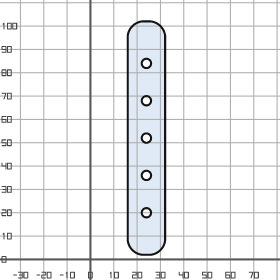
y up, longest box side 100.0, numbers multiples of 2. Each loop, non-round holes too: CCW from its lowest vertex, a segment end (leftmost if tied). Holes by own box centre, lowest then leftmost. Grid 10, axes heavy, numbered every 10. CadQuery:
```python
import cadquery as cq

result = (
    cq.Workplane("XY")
    .moveTo(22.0, 2.0)
    .lineTo(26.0, 2.0)
    .threePointArc((30.0, 4.0), (32.0, 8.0))
    .lineTo(32.0, 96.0)
    .threePointArc((30.0, 100.0), (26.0, 102.0))
    .lineTo(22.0, 102.0)
    .threePointArc((18.0, 100.0), (16.0, 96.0))
    .lineTo(16.0, 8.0)
    .threePointArc((18.0, 4.0), (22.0, 2.0))
    .close()
    .moveTo(24.0, 20.0)
    .circle(2.0)
    .moveTo(24.0, 36.0)
    .circle(2.0)
    .moveTo(24.0, 52.0)
    .circle(2.0)
    .moveTo(24.0, 68.0)
    .circle(2.0)
    .moveTo(24.0, 84.0)
    .circle(2.0)
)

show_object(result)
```